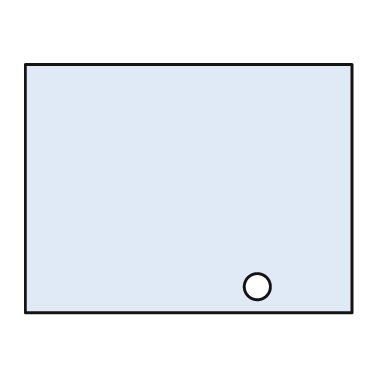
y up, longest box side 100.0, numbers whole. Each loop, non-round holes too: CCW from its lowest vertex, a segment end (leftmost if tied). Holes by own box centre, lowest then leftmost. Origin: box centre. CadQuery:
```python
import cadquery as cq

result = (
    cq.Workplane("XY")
    .moveTo(-50.0, -38.0)
    .lineTo(50.0, -38.0)
    .lineTo(50.0, 38.0)
    .lineTo(-50.0, 38.0)
    .close()
    .moveTo(21.0, -30.0)
    .circle(4.0)
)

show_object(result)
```